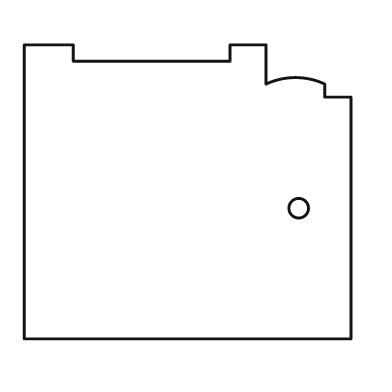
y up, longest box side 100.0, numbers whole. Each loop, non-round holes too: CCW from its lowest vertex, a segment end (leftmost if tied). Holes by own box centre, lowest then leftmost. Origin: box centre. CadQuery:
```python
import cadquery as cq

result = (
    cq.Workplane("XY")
    .moveTo(-50.0, -45.0)
    .lineTo(50.0, -45.0)
    .lineTo(50.0, 29.0)
    .lineTo(42.0, 29.0)
    .lineTo(42.0, 33.0)
    .threePointArc((33.0, 35.0), (24.0, 33.0))
    .lineTo(24.0, 45.0)
    .lineTo(13.0, 45.0)
    .lineTo(13.0, 40.0)
    .lineTo(-35.0, 40.0)
    .lineTo(-35.0, 45.0)
    .lineTo(-50.0, 45.0)
    .close()
    .moveTo(34.0, -5.0)
    .circle(3.0)
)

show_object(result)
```